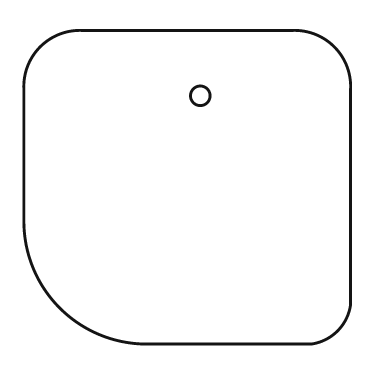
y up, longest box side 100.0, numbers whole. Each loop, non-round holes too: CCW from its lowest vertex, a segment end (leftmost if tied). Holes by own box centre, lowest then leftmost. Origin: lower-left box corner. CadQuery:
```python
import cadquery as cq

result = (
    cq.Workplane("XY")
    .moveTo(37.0, 0.0)
    .lineTo(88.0, 0.0)
    .threePointArc((96.0, 4.0), (100.0, 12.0))
    .lineTo(100.0, 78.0)
    .threePointArc((95.0, 91.0), (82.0, 96.0))
    .lineTo(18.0, 96.0)
    .threePointArc((5.0, 91.0), (0.0, 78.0))
    .lineTo(0.0, 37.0)
    .threePointArc((11.0, 11.0), (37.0, 0.0))
    .close()
    .moveTo(54.0, 76.0)
    .circle(3.0)
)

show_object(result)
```